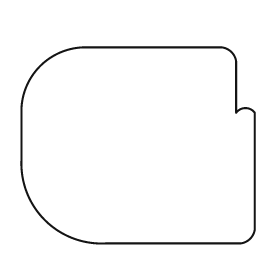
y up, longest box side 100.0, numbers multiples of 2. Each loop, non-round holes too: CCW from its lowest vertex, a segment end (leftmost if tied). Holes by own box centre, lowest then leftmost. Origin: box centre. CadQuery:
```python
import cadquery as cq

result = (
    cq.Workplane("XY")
    .moveTo(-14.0, -42.0)
    .lineTo(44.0, -42.0)
    .threePointArc((48.0, -40.0), (50.0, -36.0))
    .lineTo(50.0, 14.0)
    .threePointArc((46.0, 16.0), (42.0, 14.0))
    .lineTo(42.0, 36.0)
    .threePointArc((40.0, 40.0), (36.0, 42.0))
    .lineTo(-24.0, 42.0)
    .threePointArc((-42.0, 34.0), (-50.0, 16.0))
    .lineTo(-50.0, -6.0)
    .threePointArc((-40.0, -32.0), (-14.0, -42.0))
    .close()
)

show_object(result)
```